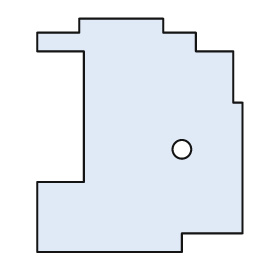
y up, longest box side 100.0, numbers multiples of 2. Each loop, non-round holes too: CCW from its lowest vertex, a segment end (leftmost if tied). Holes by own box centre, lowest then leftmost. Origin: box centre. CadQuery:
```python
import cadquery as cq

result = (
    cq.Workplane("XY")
    .moveTo(-44.0, -50.0)
    .lineTo(18.0, -50.0)
    .lineTo(18.0, -42.0)
    .lineTo(44.0, -42.0)
    .lineTo(44.0, 14.0)
    .lineTo(40.0, 14.0)
    .lineTo(40.0, 36.0)
    .lineTo(24.0, 36.0)
    .lineTo(24.0, 44.0)
    .lineTo(10.0, 44.0)
    .lineTo(10.0, 50.0)
    .lineTo(-26.0, 50.0)
    .lineTo(-26.0, 44.0)
    .lineTo(-44.0, 44.0)
    .lineTo(-44.0, 36.0)
    .lineTo(-24.0, 36.0)
    .lineTo(-24.0, -20.0)
    .lineTo(-44.0, -20.0)
    .close()
    .moveTo(18.0, -6.0)
    .circle(4.0)
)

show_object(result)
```